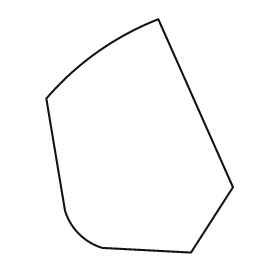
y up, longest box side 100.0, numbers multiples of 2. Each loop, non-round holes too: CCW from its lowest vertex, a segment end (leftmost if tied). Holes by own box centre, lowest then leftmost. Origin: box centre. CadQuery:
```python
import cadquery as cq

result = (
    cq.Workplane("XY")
    .moveTo(22.0, -50.0)
    .lineTo(40.0, -22.0)
    .lineTo(8.0, 50.0)
    .threePointArc((-18.0, 36.0), (-40.0, 16.0))
    .lineTo(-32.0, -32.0)
    .threePointArc((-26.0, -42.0), (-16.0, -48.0))
    .close()
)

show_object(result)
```